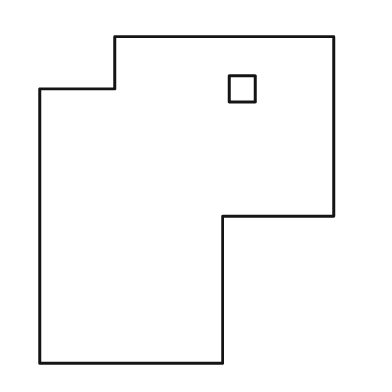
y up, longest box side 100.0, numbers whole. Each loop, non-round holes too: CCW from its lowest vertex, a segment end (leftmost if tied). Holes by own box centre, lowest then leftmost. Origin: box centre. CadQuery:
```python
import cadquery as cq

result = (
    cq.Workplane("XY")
    .moveTo(-45.0, -50.0)
    .lineTo(11.0, -50.0)
    .lineTo(11.0, -5.0)
    .lineTo(45.0, -5.0)
    .lineTo(45.0, 50.0)
    .lineTo(-22.0, 50.0)
    .lineTo(-22.0, 34.0)
    .lineTo(-45.0, 34.0)
    .close()
    .moveTo(13.0, 30.0)
    .lineTo(21.0, 30.0)
    .lineTo(21.0, 38.0)
    .lineTo(13.0, 38.0)
    .close()
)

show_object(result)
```